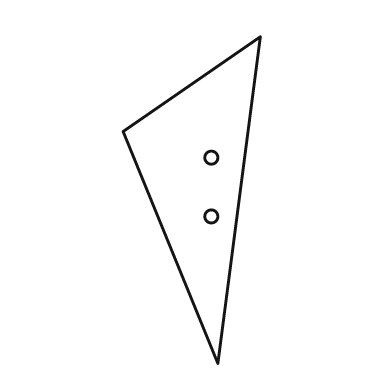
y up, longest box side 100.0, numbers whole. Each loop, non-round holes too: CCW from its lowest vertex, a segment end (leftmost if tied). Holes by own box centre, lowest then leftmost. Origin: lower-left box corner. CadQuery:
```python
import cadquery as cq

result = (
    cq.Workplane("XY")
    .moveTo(29.0, 0.0)
    .lineTo(42.0, 100.0)
    .lineTo(0.0, 71.0)
    .close()
    .moveTo(27.0, 45.0)
    .circle(2.0)
    .moveTo(27.0, 63.0)
    .circle(2.0)
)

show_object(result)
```